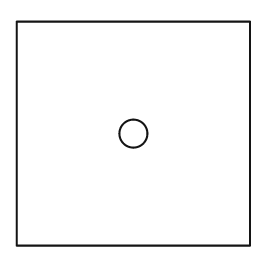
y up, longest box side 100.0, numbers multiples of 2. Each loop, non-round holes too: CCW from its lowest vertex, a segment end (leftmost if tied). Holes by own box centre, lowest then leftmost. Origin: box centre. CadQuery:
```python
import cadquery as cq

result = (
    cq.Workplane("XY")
    .moveTo(-50.0, -48.0)
    .lineTo(50.0, -48.0)
    .lineTo(50.0, 48.0)
    .lineTo(-50.0, 48.0)
    .close()
    .moveTo(0.0, 0.0)
    .circle(6.0)
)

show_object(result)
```